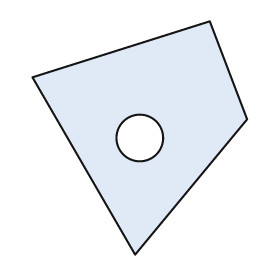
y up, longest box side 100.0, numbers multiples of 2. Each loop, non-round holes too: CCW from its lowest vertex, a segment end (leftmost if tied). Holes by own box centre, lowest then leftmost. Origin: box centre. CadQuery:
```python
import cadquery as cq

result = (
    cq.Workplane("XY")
    .moveTo(-2.0, -50.0)
    .lineTo(46.0, 8.0)
    .lineTo(30.0, 50.0)
    .lineTo(-46.0, 26.0)
    .close()
    .moveTo(0.0, 0.0)
    .circle(10.0)
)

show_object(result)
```